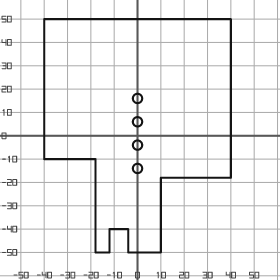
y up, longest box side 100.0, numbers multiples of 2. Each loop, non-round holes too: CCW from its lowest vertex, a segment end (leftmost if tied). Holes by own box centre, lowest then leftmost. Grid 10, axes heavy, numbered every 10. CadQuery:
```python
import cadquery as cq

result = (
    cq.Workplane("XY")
    .moveTo(-18.0, -50.0)
    .lineTo(-12.0, -50.0)
    .lineTo(-12.0, -40.0)
    .lineTo(-4.0, -40.0)
    .lineTo(-4.0, -50.0)
    .lineTo(10.0, -50.0)
    .lineTo(10.0, -18.0)
    .lineTo(40.0, -18.0)
    .lineTo(40.0, 50.0)
    .lineTo(-40.0, 50.0)
    .lineTo(-40.0, -10.0)
    .lineTo(-18.0, -10.0)
    .close()
    .moveTo(0.0, -14.0)
    .circle(2.0)
    .moveTo(0.0, -4.0)
    .circle(2.0)
    .moveTo(0.0, 6.0)
    .circle(2.0)
    .moveTo(0.0, 16.0)
    .circle(2.0)
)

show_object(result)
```